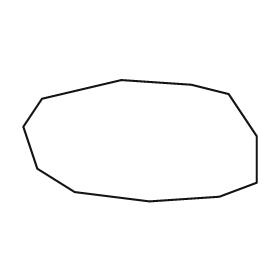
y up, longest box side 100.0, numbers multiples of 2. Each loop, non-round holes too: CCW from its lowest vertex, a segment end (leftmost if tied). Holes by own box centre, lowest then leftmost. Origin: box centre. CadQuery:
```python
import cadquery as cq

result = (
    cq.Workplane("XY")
    .moveTo(4.0, -26.0)
    .lineTo(34.0, -24.0)
    .lineTo(50.0, -18.0)
    .lineTo(50.0, 2.0)
    .lineTo(38.0, 20.0)
    .lineTo(22.0, 24.0)
    .lineTo(-8.0, 26.0)
    .lineTo(-42.0, 18.0)
    .lineTo(-50.0, 6.0)
    .lineTo(-44.0, -12.0)
    .lineTo(-28.0, -22.0)
    .close()
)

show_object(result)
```